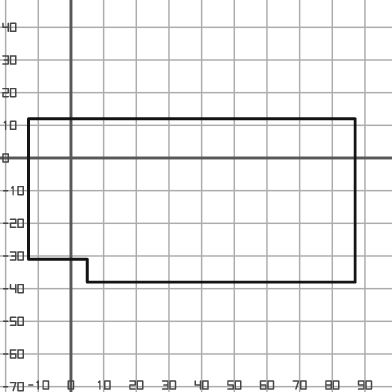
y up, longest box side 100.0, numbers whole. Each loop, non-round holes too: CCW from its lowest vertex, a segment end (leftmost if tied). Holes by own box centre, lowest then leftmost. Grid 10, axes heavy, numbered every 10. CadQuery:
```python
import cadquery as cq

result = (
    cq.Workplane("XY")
    .moveTo(5.0, -38.0)
    .lineTo(87.0, -38.0)
    .lineTo(87.0, 12.0)
    .lineTo(-13.0, 12.0)
    .lineTo(-13.0, -31.0)
    .lineTo(5.0, -31.0)
    .close()
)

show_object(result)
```